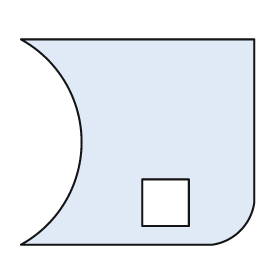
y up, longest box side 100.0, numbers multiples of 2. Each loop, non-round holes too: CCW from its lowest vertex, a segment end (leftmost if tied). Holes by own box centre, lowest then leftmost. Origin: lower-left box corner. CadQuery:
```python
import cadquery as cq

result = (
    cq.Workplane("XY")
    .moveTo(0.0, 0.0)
    .lineTo(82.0, 0.0)
    .threePointArc((94.0, 6.0), (100.0, 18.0))
    .lineTo(100.0, 88.0)
    .lineTo(0.0, 88.0)
    .threePointArc((26.0, 44.0), (0.0, 0.0))
    .close()
    .moveTo(52.0, 8.0)
    .lineTo(72.0, 8.0)
    .lineTo(72.0, 28.0)
    .lineTo(52.0, 28.0)
    .close()
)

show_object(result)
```